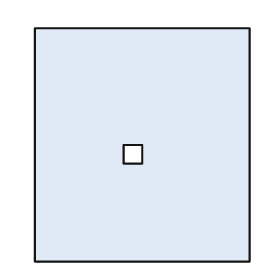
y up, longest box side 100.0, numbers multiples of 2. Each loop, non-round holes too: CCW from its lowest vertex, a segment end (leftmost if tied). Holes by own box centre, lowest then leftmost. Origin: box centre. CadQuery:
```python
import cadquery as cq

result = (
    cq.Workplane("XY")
    .moveTo(-46.0, -50.0)
    .lineTo(46.0, -50.0)
    .lineTo(46.0, 50.0)
    .lineTo(-46.0, 50.0)
    .close()
    .moveTo(-8.0, -8.0)
    .lineTo(0.0, -8.0)
    .lineTo(0.0, 0.0)
    .lineTo(-8.0, 0.0)
    .close()
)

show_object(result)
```